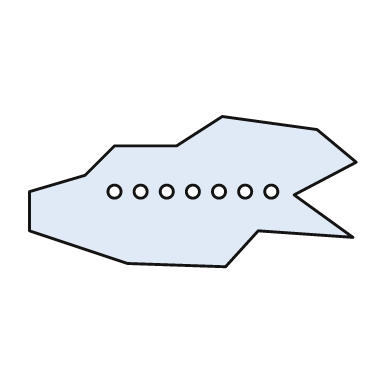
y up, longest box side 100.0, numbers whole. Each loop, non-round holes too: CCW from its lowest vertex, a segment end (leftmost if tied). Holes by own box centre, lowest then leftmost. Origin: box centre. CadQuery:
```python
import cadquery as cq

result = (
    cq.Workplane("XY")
    .moveTo(10.0, -23.0)
    .lineTo(20.0, -12.0)
    .lineTo(49.0, -14.0)
    .lineTo(31.0, -1.0)
    .lineTo(50.0, 9.0)
    .lineTo(38.0, 19.0)
    .lineTo(9.0, 23.0)
    .lineTo(-5.0, 14.0)
    .lineTo(-24.0, 14.0)
    .lineTo(-33.0, 5.0)
    .lineTo(-50.0, 0.0)
    .lineTo(-50.0, -12.0)
    .lineTo(-20.0, -22.0)
    .close()
    .moveTo(-24.0, 0.0)
    .circle(2.0)
    .moveTo(-16.0, 0.0)
    .circle(2.0)
    .moveTo(-8.0, 0.0)
    .circle(2.0)
    .moveTo(0.0, 0.0)
    .circle(2.0)
    .moveTo(8.0, 0.0)
    .circle(2.0)
    .moveTo(16.0, 0.0)
    .circle(2.0)
    .moveTo(24.0, 0.0)
    .circle(2.0)
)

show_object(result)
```